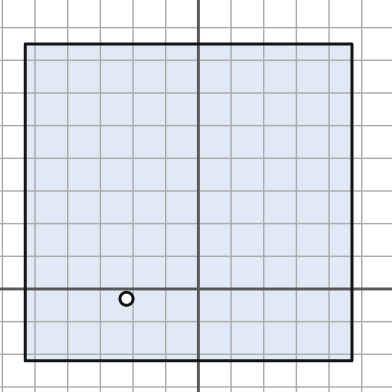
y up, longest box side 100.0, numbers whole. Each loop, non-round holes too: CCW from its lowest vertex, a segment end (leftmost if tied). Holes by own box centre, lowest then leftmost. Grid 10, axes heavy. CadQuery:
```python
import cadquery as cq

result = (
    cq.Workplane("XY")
    .moveTo(-53.0, -22.0)
    .lineTo(47.0, -22.0)
    .lineTo(47.0, 75.0)
    .lineTo(-53.0, 75.0)
    .close()
    .moveTo(-22.0, -3.0)
    .circle(2.0)
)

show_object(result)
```